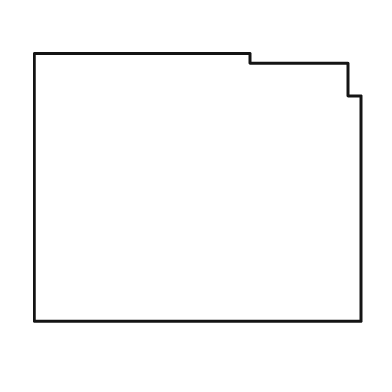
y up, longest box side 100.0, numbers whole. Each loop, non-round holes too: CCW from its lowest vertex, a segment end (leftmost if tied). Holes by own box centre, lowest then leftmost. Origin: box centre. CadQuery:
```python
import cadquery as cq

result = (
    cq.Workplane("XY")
    .moveTo(-50.0, -41.0)
    .lineTo(50.0, -41.0)
    .lineTo(50.0, 28.0)
    .lineTo(46.0, 28.0)
    .lineTo(46.0, 38.0)
    .lineTo(16.0, 38.0)
    .lineTo(16.0, 41.0)
    .lineTo(-50.0, 41.0)
    .close()
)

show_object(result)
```